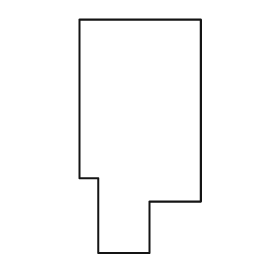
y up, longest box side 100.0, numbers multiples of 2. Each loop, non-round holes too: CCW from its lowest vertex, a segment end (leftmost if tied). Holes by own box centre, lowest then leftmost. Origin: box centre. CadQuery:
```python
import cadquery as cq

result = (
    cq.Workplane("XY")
    .moveTo(-18.0, -50.0)
    .lineTo(4.0, -50.0)
    .lineTo(4.0, -28.0)
    .lineTo(26.0, -28.0)
    .lineTo(26.0, 50.0)
    .lineTo(-26.0, 50.0)
    .lineTo(-26.0, -18.0)
    .lineTo(-18.0, -18.0)
    .close()
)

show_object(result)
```